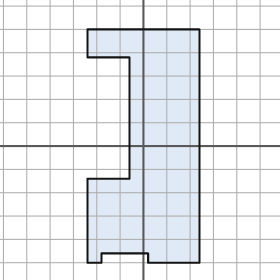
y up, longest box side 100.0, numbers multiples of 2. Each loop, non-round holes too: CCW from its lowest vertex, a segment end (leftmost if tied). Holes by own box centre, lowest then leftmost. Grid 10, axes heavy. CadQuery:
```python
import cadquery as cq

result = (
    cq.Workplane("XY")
    .moveTo(-24.0, -50.0)
    .lineTo(-18.0, -50.0)
    .lineTo(-18.0, -46.0)
    .lineTo(2.0, -46.0)
    .lineTo(2.0, -50.0)
    .lineTo(24.0, -50.0)
    .lineTo(24.0, 50.0)
    .lineTo(-24.0, 50.0)
    .lineTo(-24.0, 38.0)
    .lineTo(-6.0, 38.0)
    .lineTo(-6.0, -14.0)
    .lineTo(-24.0, -14.0)
    .close()
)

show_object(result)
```